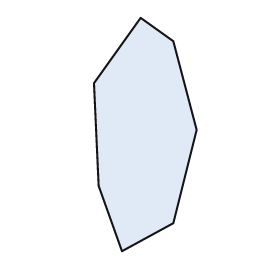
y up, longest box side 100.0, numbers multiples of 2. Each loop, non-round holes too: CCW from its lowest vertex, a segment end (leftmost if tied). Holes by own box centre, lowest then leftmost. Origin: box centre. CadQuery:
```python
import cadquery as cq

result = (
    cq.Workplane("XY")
    .moveTo(-10.0, -50.0)
    .lineTo(12.0, -38.0)
    .lineTo(22.0, 2.0)
    .lineTo(12.0, 40.0)
    .lineTo(-2.0, 50.0)
    .lineTo(-22.0, 22.0)
    .lineTo(-20.0, -22.0)
    .close()
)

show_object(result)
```